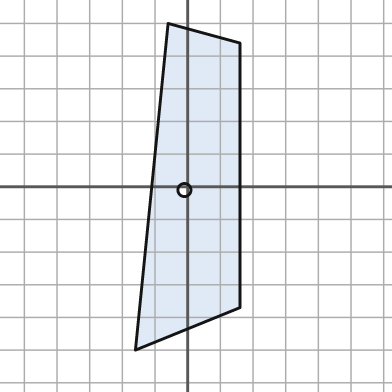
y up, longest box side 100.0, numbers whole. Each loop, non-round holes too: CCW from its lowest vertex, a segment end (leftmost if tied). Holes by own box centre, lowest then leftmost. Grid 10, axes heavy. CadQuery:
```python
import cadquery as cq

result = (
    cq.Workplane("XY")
    .moveTo(-16.0, -50.0)
    .lineTo(16.0, -37.0)
    .lineTo(16.0, 44.0)
    .lineTo(-6.0, 50.0)
    .close()
    .moveTo(-1.0, -1.0)
    .circle(2.0)
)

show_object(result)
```